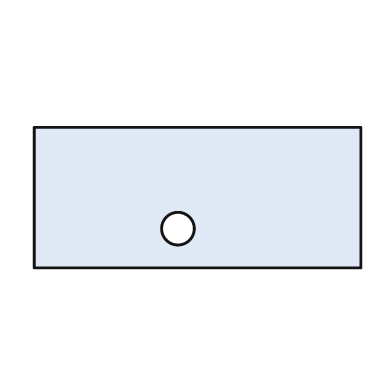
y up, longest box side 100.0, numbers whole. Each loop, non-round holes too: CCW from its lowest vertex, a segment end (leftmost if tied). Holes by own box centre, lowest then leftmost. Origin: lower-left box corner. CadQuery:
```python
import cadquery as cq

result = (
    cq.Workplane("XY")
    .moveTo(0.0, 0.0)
    .lineTo(100.0, 0.0)
    .lineTo(100.0, 43.0)
    .lineTo(0.0, 43.0)
    .close()
    .moveTo(44.0, 12.0)
    .circle(5.0)
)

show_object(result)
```